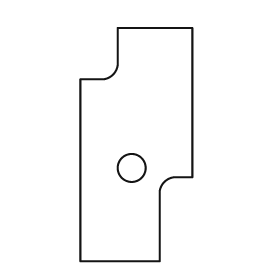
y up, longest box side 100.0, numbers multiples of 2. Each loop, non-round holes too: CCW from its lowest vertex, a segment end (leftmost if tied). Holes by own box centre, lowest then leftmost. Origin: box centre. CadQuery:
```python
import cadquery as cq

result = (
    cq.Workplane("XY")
    .moveTo(-24.0, -50.0)
    .lineTo(10.0, -50.0)
    .lineTo(10.0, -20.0)
    .threePointArc((12.0, -16.0), (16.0, -14.0))
    .lineTo(24.0, -14.0)
    .lineTo(24.0, 50.0)
    .lineTo(-8.0, 50.0)
    .lineTo(-8.0, 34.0)
    .threePointArc((-10.0, 30.0), (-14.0, 28.0))
    .lineTo(-24.0, 28.0)
    .close()
    .moveTo(-2.0, -10.0)
    .circle(6.0)
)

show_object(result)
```